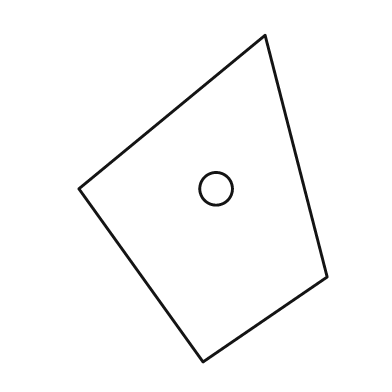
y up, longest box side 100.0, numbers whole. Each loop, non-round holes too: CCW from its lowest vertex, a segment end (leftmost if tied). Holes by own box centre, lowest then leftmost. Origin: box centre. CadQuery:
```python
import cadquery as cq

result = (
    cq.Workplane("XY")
    .moveTo(0.0, -50.0)
    .lineTo(38.0, -24.0)
    .lineTo(19.0, 50.0)
    .lineTo(-38.0, 3.0)
    .close()
    .moveTo(4.0, 3.0)
    .circle(5.0)
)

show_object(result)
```